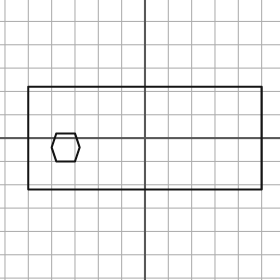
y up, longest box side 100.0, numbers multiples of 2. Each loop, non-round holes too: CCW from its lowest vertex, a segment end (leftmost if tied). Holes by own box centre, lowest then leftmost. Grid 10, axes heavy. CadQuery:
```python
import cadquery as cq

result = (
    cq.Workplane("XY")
    .moveTo(-50.0, -22.0)
    .lineTo(50.0, -22.0)
    .lineTo(50.0, 22.0)
    .lineTo(-50.0, 22.0)
    .close()
    .moveTo(-38.0, -10.0)
    .lineTo(-30.0, -10.0)
    .lineTo(-28.0, -4.0)
    .lineTo(-30.0, 2.0)
    .lineTo(-38.0, 2.0)
    .lineTo(-40.0, -4.0)
    .close()
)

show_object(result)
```